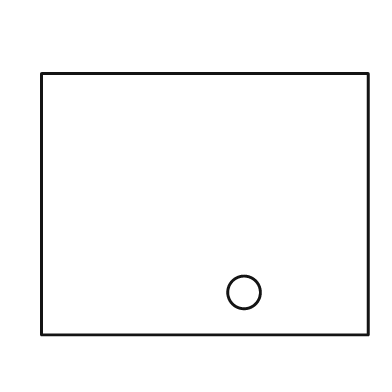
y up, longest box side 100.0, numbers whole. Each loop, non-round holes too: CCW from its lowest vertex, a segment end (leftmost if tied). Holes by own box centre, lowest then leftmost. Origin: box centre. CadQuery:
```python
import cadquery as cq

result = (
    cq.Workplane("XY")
    .moveTo(-50.0, -40.0)
    .lineTo(50.0, -40.0)
    .lineTo(50.0, 40.0)
    .lineTo(-50.0, 40.0)
    .close()
    .moveTo(12.0, -27.0)
    .circle(5.0)
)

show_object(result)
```